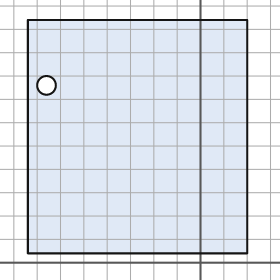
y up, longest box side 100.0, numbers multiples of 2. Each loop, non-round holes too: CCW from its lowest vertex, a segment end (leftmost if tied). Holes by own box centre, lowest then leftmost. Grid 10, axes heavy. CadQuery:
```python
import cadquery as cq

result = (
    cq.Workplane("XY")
    .moveTo(-74.0, 4.0)
    .lineTo(20.0, 4.0)
    .lineTo(20.0, 104.0)
    .lineTo(-74.0, 104.0)
    .close()
    .moveTo(-66.0, 76.0)
    .circle(4.0)
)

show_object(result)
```